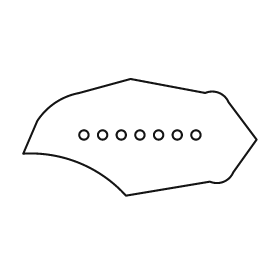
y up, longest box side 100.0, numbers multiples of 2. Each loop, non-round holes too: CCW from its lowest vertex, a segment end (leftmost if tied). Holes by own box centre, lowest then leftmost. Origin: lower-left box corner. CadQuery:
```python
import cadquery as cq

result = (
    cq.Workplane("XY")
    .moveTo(44.0, 0.0)
    .lineTo(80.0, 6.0)
    .threePointArc((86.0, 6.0), (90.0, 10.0))
    .lineTo(100.0, 24.0)
    .lineTo(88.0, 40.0)
    .threePointArc((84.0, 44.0), (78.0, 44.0))
    .lineTo(46.0, 50.0)
    .lineTo(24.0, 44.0)
    .threePointArc((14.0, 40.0), (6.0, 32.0))
    .lineTo(0.0, 18.0)
    .threePointArc((24.0, 14.0), (44.0, 0.0))
    .close()
    .moveTo(26.0, 26.0)
    .circle(2.0)
    .moveTo(34.0, 26.0)
    .circle(2.0)
    .moveTo(42.0, 26.0)
    .circle(2.0)
    .moveTo(50.0, 26.0)
    .circle(2.0)
    .moveTo(58.0, 26.0)
    .circle(2.0)
    .moveTo(66.0, 26.0)
    .circle(2.0)
    .moveTo(74.0, 26.0)
    .circle(2.0)
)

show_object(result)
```